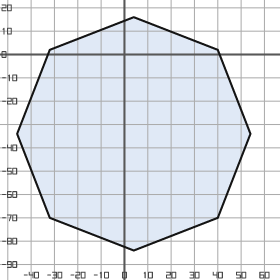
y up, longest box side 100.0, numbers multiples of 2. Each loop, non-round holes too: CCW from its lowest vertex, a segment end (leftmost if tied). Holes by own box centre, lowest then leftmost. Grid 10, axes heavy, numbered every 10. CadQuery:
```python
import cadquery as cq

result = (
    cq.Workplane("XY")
    .moveTo(4.0, -84.0)
    .lineTo(40.0, -70.0)
    .lineTo(54.0, -34.0)
    .lineTo(40.0, 2.0)
    .lineTo(4.0, 16.0)
    .lineTo(-32.0, 2.0)
    .lineTo(-46.0, -34.0)
    .lineTo(-32.0, -70.0)
    .close()
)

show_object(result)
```